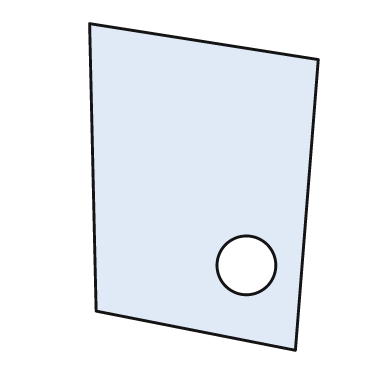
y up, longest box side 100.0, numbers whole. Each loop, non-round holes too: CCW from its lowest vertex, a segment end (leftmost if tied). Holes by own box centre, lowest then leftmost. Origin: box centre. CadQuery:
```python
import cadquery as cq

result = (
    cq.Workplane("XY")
    .moveTo(28.0, -50.0)
    .lineTo(35.0, 39.0)
    .lineTo(-35.0, 50.0)
    .lineTo(-33.0, -38.0)
    .close()
    .moveTo(13.0, -24.0)
    .circle(9.0)
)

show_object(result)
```